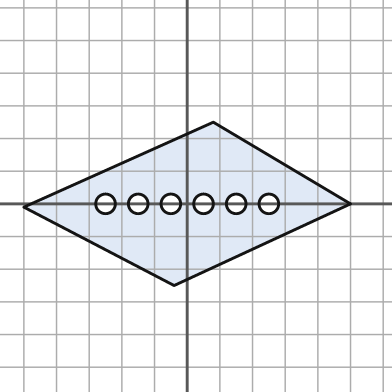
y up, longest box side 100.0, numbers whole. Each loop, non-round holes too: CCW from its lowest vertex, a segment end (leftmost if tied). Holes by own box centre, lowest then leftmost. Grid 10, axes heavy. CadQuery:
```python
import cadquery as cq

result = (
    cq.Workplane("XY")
    .moveTo(-4.0, -25.0)
    .lineTo(50.0, 0.0)
    .lineTo(8.0, 25.0)
    .lineTo(-50.0, -1.0)
    .close()
    .moveTo(-25.0, 0.0)
    .circle(3.0)
    .moveTo(-15.0, 0.0)
    .circle(3.0)
    .moveTo(-5.0, 0.0)
    .circle(3.0)
    .moveTo(5.0, 0.0)
    .circle(3.0)
    .moveTo(15.0, 0.0)
    .circle(3.0)
    .moveTo(25.0, 0.0)
    .circle(3.0)
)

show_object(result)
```